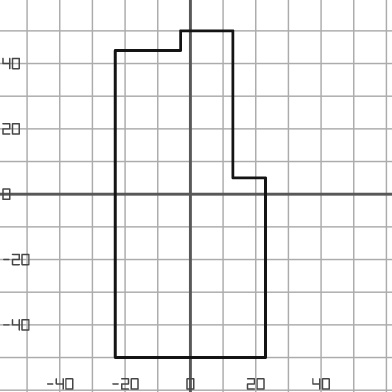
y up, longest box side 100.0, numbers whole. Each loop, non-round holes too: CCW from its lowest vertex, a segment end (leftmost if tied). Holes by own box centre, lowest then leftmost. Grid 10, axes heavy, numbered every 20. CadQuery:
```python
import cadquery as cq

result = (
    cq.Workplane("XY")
    .moveTo(-23.0, -50.0)
    .lineTo(23.0, -50.0)
    .lineTo(23.0, 5.0)
    .lineTo(13.0, 5.0)
    .lineTo(13.0, 50.0)
    .lineTo(-3.0, 50.0)
    .lineTo(-3.0, 44.0)
    .lineTo(-23.0, 44.0)
    .close()
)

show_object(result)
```